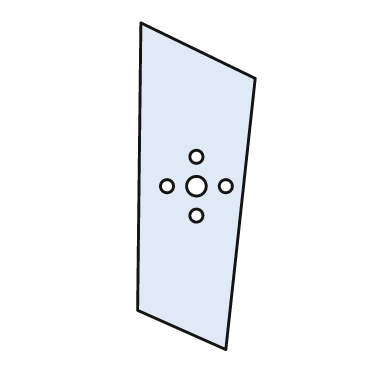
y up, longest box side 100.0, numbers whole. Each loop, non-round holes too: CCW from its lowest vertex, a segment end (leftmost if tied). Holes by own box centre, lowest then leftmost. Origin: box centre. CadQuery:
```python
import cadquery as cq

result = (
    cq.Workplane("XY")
    .moveTo(9.0, -50.0)
    .lineTo(18.0, 33.0)
    .lineTo(-17.0, 50.0)
    .lineTo(-18.0, -38.0)
    .close()
    .moveTo(0.0, -9.0)
    .circle(2.0)
    .moveTo(-9.0, 0.0)
    .circle(2.0)
    .moveTo(0.0, 0.0)
    .circle(3.0)
    .moveTo(9.0, 0.0)
    .circle(2.0)
    .moveTo(0.0, 9.0)
    .circle(2.0)
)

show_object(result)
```